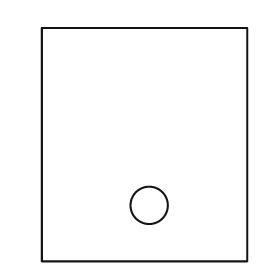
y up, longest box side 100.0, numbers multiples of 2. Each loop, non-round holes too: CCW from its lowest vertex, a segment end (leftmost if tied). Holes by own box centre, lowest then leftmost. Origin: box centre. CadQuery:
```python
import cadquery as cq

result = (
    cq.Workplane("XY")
    .moveTo(-44.0, -50.0)
    .lineTo(44.0, -50.0)
    .lineTo(44.0, 50.0)
    .lineTo(-44.0, 50.0)
    .close()
    .moveTo(2.0, -26.0)
    .circle(8.0)
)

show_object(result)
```